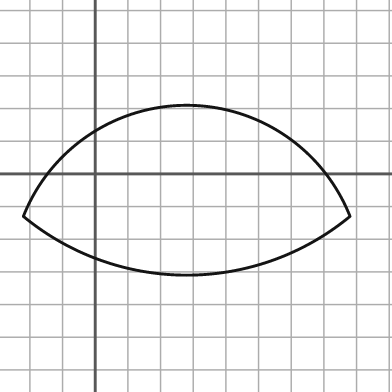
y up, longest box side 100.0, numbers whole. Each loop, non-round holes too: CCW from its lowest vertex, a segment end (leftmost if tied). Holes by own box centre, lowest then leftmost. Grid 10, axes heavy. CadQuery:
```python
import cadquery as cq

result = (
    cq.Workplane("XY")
    .moveTo(-22.0, -13.0)
    .threePointArc((28.0, -31.0), (78.0, -13.0))
    .threePointArc((28.0, 21.0), (-22.0, -13.0))
    .close()
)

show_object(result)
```